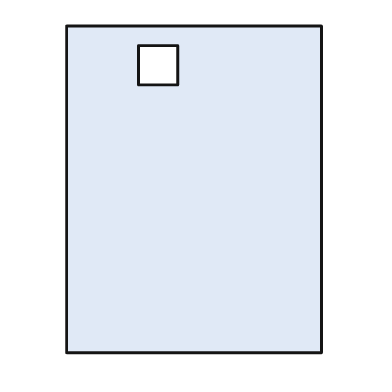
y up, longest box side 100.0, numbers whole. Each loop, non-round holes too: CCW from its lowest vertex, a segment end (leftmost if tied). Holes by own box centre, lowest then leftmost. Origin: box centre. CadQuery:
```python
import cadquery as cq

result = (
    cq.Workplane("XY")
    .moveTo(-39.0, -50.0)
    .lineTo(39.0, -50.0)
    .lineTo(39.0, 50.0)
    .lineTo(-39.0, 50.0)
    .close()
    .moveTo(-17.0, 32.0)
    .lineTo(-5.0, 32.0)
    .lineTo(-5.0, 44.0)
    .lineTo(-17.0, 44.0)
    .close()
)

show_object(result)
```